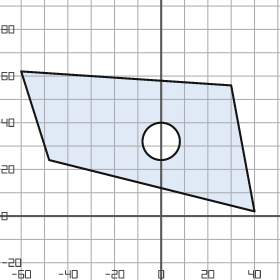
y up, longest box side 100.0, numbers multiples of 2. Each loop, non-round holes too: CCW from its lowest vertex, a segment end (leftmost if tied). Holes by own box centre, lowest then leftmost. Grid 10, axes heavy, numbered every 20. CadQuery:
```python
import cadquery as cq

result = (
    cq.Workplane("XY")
    .moveTo(40.0, 2.0)
    .lineTo(30.0, 56.0)
    .lineTo(-60.0, 62.0)
    .lineTo(-48.0, 24.0)
    .close()
    .moveTo(0.0, 32.0)
    .circle(8.0)
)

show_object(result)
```